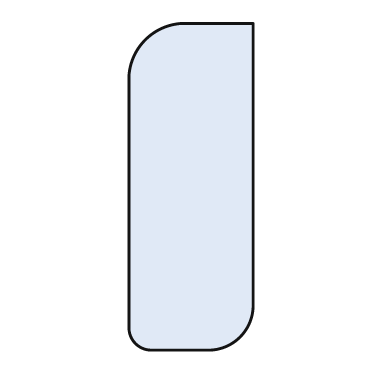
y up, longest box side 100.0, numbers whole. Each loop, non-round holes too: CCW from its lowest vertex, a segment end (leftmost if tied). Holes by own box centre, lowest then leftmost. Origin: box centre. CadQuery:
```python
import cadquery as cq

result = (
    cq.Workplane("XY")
    .moveTo(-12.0, -50.0)
    .lineTo(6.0, -50.0)
    .threePointArc((15.0, -46.0), (19.0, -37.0))
    .lineTo(19.0, 50.0)
    .lineTo(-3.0, 50.0)
    .threePointArc((-14.0, 45.0), (-19.0, 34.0))
    .lineTo(-19.0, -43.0)
    .threePointArc((-17.0, -48.0), (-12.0, -50.0))
    .close()
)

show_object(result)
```